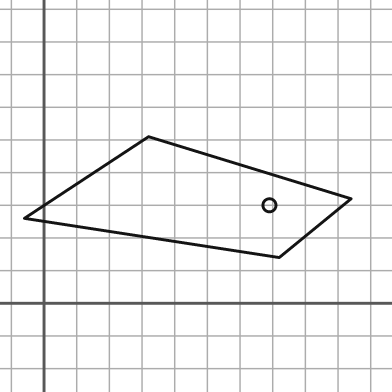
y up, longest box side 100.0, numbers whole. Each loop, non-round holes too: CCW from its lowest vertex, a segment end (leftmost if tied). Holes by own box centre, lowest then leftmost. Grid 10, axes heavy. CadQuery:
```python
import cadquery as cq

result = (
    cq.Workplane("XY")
    .moveTo(72.0, 14.0)
    .lineTo(94.0, 32.0)
    .lineTo(32.0, 51.0)
    .lineTo(-6.0, 26.0)
    .close()
    .moveTo(69.0, 30.0)
    .circle(2.0)
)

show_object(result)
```